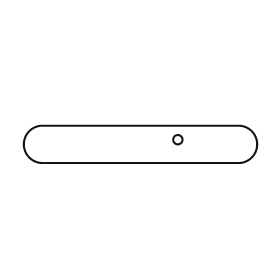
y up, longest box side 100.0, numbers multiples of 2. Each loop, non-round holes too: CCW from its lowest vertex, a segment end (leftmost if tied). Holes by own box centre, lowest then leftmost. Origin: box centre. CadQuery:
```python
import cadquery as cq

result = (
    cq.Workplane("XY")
    .moveTo(-42.0, -8.0)
    .lineTo(42.0, -8.0)
    .threePointArc((50.0, 0.0), (42.0, 8.0))
    .lineTo(-42.0, 8.0)
    .threePointArc((-50.0, 0.0), (-42.0, -8.0))
    .close()
    .moveTo(16.0, 2.0)
    .circle(2.0)
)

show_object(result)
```